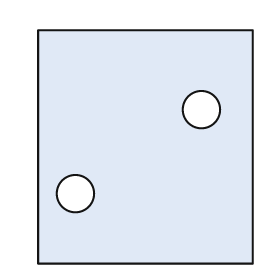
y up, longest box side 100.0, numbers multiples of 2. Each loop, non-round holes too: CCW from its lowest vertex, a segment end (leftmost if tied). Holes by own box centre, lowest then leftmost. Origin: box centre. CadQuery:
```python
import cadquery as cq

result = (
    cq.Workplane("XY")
    .moveTo(-46.0, -50.0)
    .lineTo(46.0, -50.0)
    .lineTo(46.0, 50.0)
    .lineTo(-46.0, 50.0)
    .close()
    .moveTo(-30.0, -20.0)
    .circle(8.0)
    .moveTo(24.0, 16.0)
    .circle(8.0)
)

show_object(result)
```